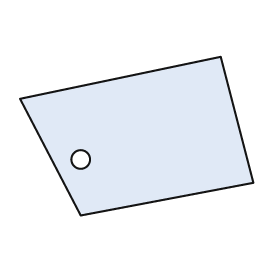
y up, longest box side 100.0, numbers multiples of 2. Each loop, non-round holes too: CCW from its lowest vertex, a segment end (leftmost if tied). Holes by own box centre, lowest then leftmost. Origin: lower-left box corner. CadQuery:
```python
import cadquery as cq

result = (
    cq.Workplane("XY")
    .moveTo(26.0, 0.0)
    .lineTo(100.0, 14.0)
    .lineTo(86.0, 68.0)
    .lineTo(0.0, 50.0)
    .close()
    .moveTo(26.0, 24.0)
    .circle(4.0)
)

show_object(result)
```